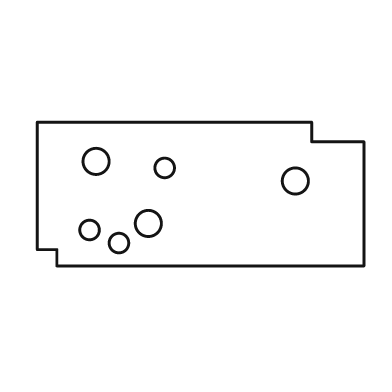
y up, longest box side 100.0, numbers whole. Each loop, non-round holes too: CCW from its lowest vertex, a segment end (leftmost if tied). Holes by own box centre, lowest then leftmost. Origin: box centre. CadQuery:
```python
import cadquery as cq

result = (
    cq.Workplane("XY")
    .moveTo(-44.0, -22.0)
    .lineTo(50.0, -22.0)
    .lineTo(50.0, 16.0)
    .lineTo(34.0, 16.0)
    .lineTo(34.0, 22.0)
    .lineTo(-50.0, 22.0)
    .lineTo(-50.0, -17.0)
    .lineTo(-44.0, -17.0)
    .close()
    .moveTo(-25.0, -15.0)
    .circle(3.0)
    .moveTo(-34.0, -11.0)
    .circle(3.0)
    .moveTo(-16.0, -9.0)
    .circle(4.0)
    .moveTo(29.0, 4.0)
    .circle(4.0)
    .moveTo(-11.0, 8.0)
    .circle(3.0)
    .moveTo(-32.0, 10.0)
    .circle(4.0)
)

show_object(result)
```